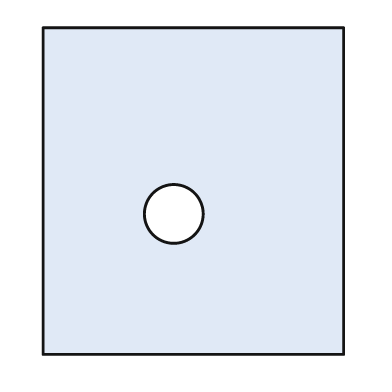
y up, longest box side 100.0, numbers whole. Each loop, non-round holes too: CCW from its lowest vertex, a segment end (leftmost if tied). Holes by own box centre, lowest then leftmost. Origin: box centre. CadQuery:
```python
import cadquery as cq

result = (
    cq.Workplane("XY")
    .moveTo(-46.0, -50.0)
    .lineTo(46.0, -50.0)
    .lineTo(46.0, 50.0)
    .lineTo(-46.0, 50.0)
    .close()
    .moveTo(-6.0, -7.0)
    .circle(9.0)
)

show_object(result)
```